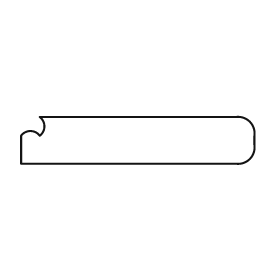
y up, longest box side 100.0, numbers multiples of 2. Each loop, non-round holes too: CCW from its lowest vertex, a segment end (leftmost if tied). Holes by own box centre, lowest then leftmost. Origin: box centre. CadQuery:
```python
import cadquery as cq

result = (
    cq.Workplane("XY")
    .moveTo(-50.0, -10.0)
    .lineTo(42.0, -10.0)
    .threePointArc((48.0, -8.0), (50.0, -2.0))
    .lineTo(50.0, 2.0)
    .threePointArc((48.0, 8.0), (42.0, 10.0))
    .lineTo(-42.0, 10.0)
    .threePointArc((-40.0, 6.0), (-42.0, 2.0))
    .threePointArc((-46.0, 4.0), (-50.0, 2.0))
    .close()
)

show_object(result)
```